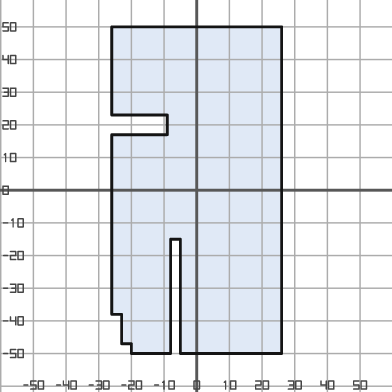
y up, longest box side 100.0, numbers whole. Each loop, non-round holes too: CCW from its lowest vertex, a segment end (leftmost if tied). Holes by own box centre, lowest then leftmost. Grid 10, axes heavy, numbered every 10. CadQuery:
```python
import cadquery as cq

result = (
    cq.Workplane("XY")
    .moveTo(-20.0, -50.0)
    .lineTo(-8.0, -50.0)
    .lineTo(-8.0, -15.0)
    .lineTo(-5.0, -15.0)
    .lineTo(-5.0, -50.0)
    .lineTo(26.0, -50.0)
    .lineTo(26.0, 50.0)
    .lineTo(-26.0, 50.0)
    .lineTo(-26.0, 23.0)
    .lineTo(-9.0, 23.0)
    .lineTo(-9.0, 17.0)
    .lineTo(-26.0, 17.0)
    .lineTo(-26.0, -38.0)
    .lineTo(-23.0, -38.0)
    .lineTo(-23.0, -47.0)
    .lineTo(-20.0, -47.0)
    .close()
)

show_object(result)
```